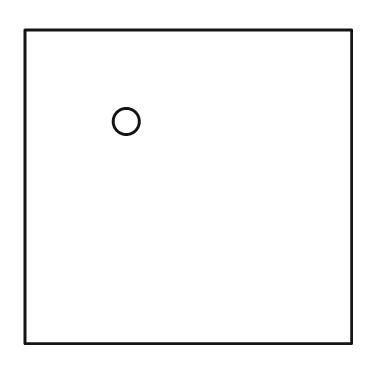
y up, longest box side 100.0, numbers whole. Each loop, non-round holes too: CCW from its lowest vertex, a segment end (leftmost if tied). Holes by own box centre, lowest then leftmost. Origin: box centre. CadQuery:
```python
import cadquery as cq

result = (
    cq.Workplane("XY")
    .moveTo(-50.0, -48.0)
    .lineTo(50.0, -48.0)
    .lineTo(50.0, 48.0)
    .lineTo(-50.0, 48.0)
    .close()
    .moveTo(-19.0, 20.0)
    .circle(4.0)
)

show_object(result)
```